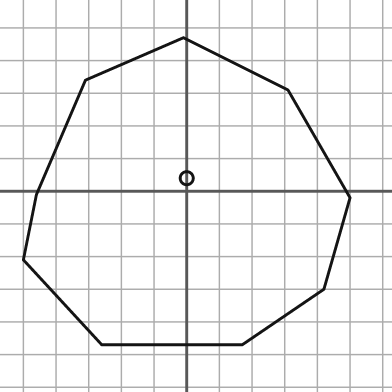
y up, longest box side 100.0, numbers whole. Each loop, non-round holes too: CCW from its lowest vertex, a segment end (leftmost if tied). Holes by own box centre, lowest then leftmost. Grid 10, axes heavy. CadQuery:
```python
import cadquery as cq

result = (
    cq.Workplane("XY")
    .moveTo(-26.0, -47.0)
    .lineTo(17.0, -47.0)
    .lineTo(42.0, -30.0)
    .lineTo(50.0, -2.0)
    .lineTo(31.0, 31.0)
    .lineTo(-1.0, 47.0)
    .lineTo(-31.0, 34.0)
    .lineTo(-46.0, -1.0)
    .lineTo(-50.0, -21.0)
    .close()
    .moveTo(0.0, 4.0)
    .circle(2.0)
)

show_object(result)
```